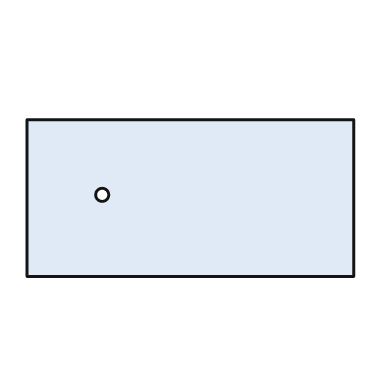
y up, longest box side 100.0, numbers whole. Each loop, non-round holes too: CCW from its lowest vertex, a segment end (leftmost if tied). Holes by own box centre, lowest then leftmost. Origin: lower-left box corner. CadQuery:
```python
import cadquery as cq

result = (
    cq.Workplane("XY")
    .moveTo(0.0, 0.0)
    .lineTo(100.0, 0.0)
    .lineTo(100.0, 48.0)
    .lineTo(0.0, 48.0)
    .close()
    .moveTo(23.0, 25.0)
    .circle(2.0)
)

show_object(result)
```